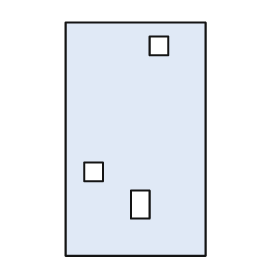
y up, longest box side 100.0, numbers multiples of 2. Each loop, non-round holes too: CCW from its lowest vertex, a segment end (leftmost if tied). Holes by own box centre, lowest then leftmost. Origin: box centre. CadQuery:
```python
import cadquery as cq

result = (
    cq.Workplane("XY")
    .moveTo(-30.0, -50.0)
    .lineTo(30.0, -50.0)
    .lineTo(30.0, 50.0)
    .lineTo(-30.0, 50.0)
    .close()
    .moveTo(-2.0, -34.0)
    .lineTo(6.0, -34.0)
    .lineTo(6.0, -22.0)
    .lineTo(-2.0, -22.0)
    .close()
    .moveTo(-22.0, -18.0)
    .lineTo(-14.0, -18.0)
    .lineTo(-14.0, -10.0)
    .lineTo(-22.0, -10.0)
    .close()
    .moveTo(6.0, 36.0)
    .lineTo(14.0, 36.0)
    .lineTo(14.0, 44.0)
    .lineTo(6.0, 44.0)
    .close()
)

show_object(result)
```